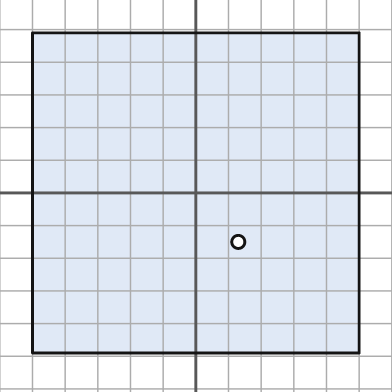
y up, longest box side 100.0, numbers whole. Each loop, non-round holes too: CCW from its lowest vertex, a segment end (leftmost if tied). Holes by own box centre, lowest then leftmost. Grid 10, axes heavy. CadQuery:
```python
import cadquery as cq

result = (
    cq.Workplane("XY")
    .moveTo(-50.0, -49.0)
    .lineTo(50.0, -49.0)
    .lineTo(50.0, 49.0)
    .lineTo(-50.0, 49.0)
    .close()
    .moveTo(13.0, -15.0)
    .circle(2.0)
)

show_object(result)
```